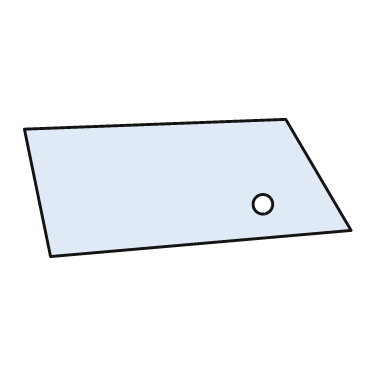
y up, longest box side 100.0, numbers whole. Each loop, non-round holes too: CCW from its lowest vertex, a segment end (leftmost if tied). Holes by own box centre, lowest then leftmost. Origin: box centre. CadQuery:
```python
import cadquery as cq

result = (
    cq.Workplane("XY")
    .moveTo(-42.0, -21.0)
    .lineTo(50.0, -13.0)
    .lineTo(30.0, 21.0)
    .lineTo(-50.0, 18.0)
    .close()
    .moveTo(23.0, -5.0)
    .circle(3.0)
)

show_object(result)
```